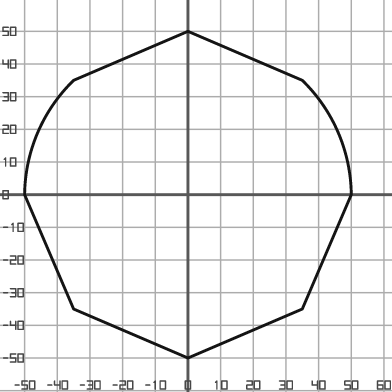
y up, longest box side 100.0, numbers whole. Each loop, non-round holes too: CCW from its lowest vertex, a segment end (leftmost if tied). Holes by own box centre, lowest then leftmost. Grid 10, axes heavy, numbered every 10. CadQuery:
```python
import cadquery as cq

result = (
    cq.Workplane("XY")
    .moveTo(0.0, -50.0)
    .lineTo(35.0, -35.0)
    .lineTo(50.0, 0.0)
    .threePointArc((46.0, 19.0), (35.0, 35.0))
    .lineTo(0.0, 50.0)
    .lineTo(-35.0, 35.0)
    .threePointArc((-46.0, 19.0), (-50.0, 0.0))
    .lineTo(-35.0, -35.0)
    .close()
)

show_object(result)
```